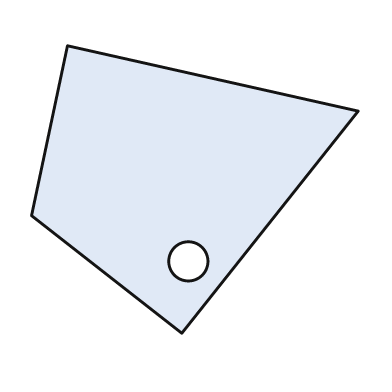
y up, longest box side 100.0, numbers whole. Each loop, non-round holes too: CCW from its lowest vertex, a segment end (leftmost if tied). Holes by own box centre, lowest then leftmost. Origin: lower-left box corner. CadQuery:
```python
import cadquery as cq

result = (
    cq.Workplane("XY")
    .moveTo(46.0, 0.0)
    .lineTo(100.0, 68.0)
    .lineTo(11.0, 88.0)
    .lineTo(0.0, 36.0)
    .close()
    .moveTo(48.0, 22.0)
    .circle(6.0)
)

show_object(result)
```